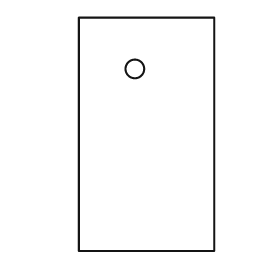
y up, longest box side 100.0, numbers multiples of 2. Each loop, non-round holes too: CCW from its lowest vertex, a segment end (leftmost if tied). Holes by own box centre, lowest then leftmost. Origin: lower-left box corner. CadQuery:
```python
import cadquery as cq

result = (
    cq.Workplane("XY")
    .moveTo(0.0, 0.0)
    .lineTo(58.0, 0.0)
    .lineTo(58.0, 100.0)
    .lineTo(0.0, 100.0)
    .close()
    .moveTo(24.0, 78.0)
    .circle(4.0)
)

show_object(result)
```